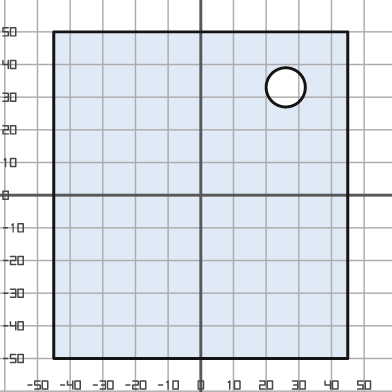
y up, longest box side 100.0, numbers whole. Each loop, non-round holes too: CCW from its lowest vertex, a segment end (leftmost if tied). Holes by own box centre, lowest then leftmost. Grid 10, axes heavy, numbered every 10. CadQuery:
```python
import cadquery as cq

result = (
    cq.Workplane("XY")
    .moveTo(-45.0, -50.0)
    .lineTo(45.0, -50.0)
    .lineTo(45.0, 50.0)
    .lineTo(-45.0, 50.0)
    .close()
    .moveTo(26.0, 33.0)
    .circle(6.0)
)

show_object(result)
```